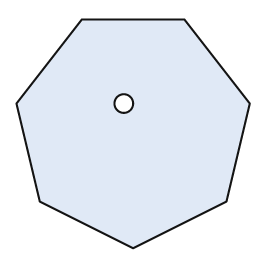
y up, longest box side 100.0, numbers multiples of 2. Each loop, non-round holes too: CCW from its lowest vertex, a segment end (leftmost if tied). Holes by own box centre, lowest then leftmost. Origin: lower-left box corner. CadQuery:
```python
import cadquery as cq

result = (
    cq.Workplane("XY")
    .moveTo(50.0, 0.0)
    .lineTo(90.0, 20.0)
    .lineTo(100.0, 62.0)
    .lineTo(72.0, 98.0)
    .lineTo(28.0, 98.0)
    .lineTo(0.0, 62.0)
    .lineTo(10.0, 20.0)
    .close()
    .moveTo(46.0, 62.0)
    .circle(4.0)
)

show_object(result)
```